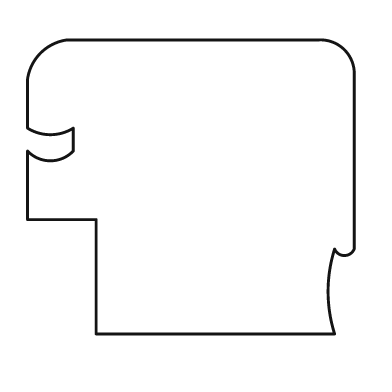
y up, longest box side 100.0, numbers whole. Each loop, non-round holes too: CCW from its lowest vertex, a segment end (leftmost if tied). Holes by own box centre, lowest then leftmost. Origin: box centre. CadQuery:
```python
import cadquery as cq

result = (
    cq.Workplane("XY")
    .moveTo(-29.0, -45.0)
    .lineTo(44.0, -45.0)
    .threePointArc((42.0, -32.0), (44.0, -19.0))
    .threePointArc((47.0, -21.0), (50.0, -19.0))
    .lineTo(50.0, 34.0)
    .threePointArc((47.0, 42.0), (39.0, 45.0))
    .lineTo(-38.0, 45.0)
    .threePointArc((-46.0, 41.0), (-50.0, 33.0))
    .lineTo(-50.0, 18.0)
    .threePointArc((-43.0, 16.0), (-36.0, 18.0))
    .lineTo(-36.0, 11.0)
    .threePointArc((-43.0, 8.0), (-50.0, 11.0))
    .lineTo(-50.0, -10.0)
    .lineTo(-29.0, -10.0)
    .close()
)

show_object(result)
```